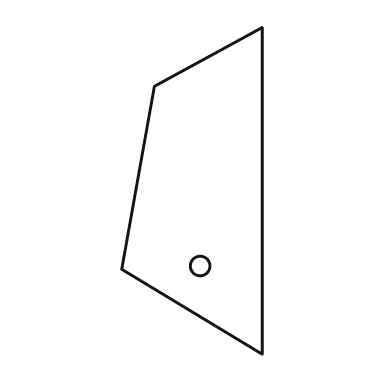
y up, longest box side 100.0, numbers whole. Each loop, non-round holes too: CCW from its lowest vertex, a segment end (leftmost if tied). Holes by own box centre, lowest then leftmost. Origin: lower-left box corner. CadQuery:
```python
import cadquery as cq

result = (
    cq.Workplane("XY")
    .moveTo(43.0, 0.0)
    .lineTo(43.0, 100.0)
    .lineTo(10.0, 82.0)
    .lineTo(0.0, 26.0)
    .close()
    .moveTo(24.0, 27.0)
    .circle(3.0)
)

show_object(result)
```